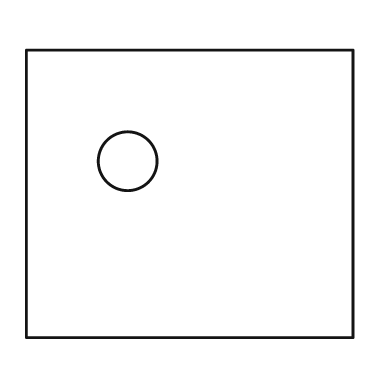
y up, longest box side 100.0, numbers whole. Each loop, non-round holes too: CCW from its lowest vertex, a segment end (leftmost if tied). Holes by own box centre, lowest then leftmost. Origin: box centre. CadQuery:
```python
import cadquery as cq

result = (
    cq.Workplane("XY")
    .moveTo(-50.0, -44.0)
    .lineTo(50.0, -44.0)
    .lineTo(50.0, 44.0)
    .lineTo(-50.0, 44.0)
    .close()
    .moveTo(-19.0, 10.0)
    .circle(9.0)
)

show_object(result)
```